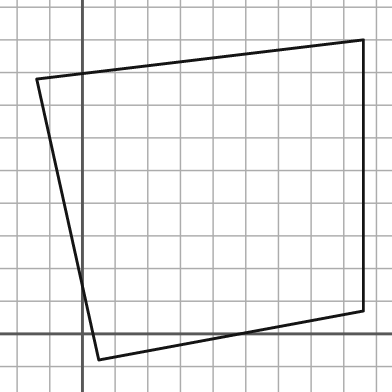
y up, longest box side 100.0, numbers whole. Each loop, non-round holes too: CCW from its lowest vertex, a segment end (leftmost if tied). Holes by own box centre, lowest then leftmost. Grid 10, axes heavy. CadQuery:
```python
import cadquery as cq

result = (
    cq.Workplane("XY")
    .moveTo(5.0, -8.0)
    .lineTo(86.0, 7.0)
    .lineTo(86.0, 90.0)
    .lineTo(-14.0, 78.0)
    .close()
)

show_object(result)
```